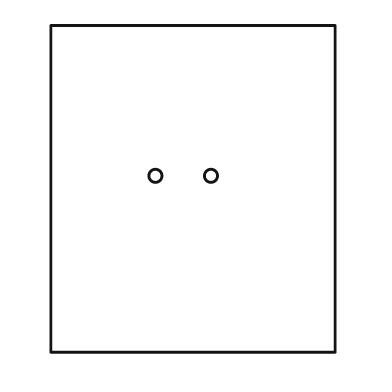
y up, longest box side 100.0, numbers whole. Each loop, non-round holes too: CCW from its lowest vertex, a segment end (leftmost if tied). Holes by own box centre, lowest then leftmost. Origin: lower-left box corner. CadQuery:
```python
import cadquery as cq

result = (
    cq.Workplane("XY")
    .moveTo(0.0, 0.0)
    .lineTo(87.0, 0.0)
    .lineTo(87.0, 100.0)
    .lineTo(0.0, 100.0)
    .close()
    .moveTo(32.0, 54.0)
    .circle(2.0)
    .moveTo(49.0, 54.0)
    .circle(2.0)
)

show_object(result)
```